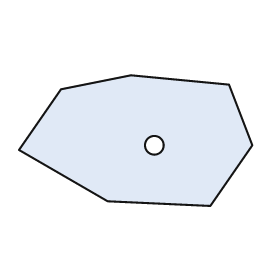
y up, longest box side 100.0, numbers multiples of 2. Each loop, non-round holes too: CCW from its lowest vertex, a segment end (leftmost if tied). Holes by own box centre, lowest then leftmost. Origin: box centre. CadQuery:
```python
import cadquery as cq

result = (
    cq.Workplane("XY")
    .moveTo(32.0, -28.0)
    .lineTo(50.0, -2.0)
    .lineTo(40.0, 24.0)
    .lineTo(-2.0, 28.0)
    .lineTo(-32.0, 22.0)
    .lineTo(-50.0, -4.0)
    .lineTo(-12.0, -26.0)
    .close()
    .moveTo(8.0, -2.0)
    .circle(4.0)
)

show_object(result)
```